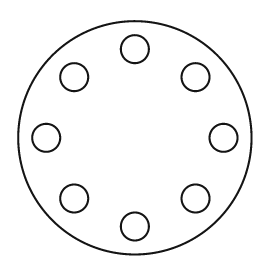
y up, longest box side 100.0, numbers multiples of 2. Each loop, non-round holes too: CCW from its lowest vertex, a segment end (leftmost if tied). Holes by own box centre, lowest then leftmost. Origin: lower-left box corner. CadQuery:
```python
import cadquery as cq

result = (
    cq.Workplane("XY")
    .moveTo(50.0, 50.0)
    .circle(50.0)
    .moveTo(50.0, 12.0)
    .circle(6.0)
    .moveTo(24.0, 24.0)
    .circle(6.0)
    .moveTo(76.0, 24.0)
    .circle(6.0)
    .moveTo(12.0, 50.0)
    .circle(6.0)
    .moveTo(88.0, 50.0)
    .circle(6.0)
    .moveTo(24.0, 76.0)
    .circle(6.0)
    .moveTo(76.0, 76.0)
    .circle(6.0)
    .moveTo(50.0, 88.0)
    .circle(6.0)
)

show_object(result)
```